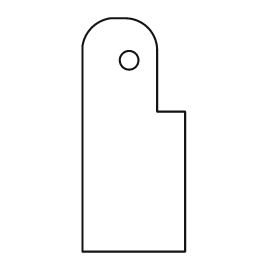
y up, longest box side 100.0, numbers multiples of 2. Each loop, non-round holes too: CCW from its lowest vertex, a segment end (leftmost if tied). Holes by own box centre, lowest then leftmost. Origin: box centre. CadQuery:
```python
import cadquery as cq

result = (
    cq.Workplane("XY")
    .moveTo(-22.0, -50.0)
    .lineTo(22.0, -50.0)
    .lineTo(22.0, 10.0)
    .lineTo(10.0, 10.0)
    .lineTo(10.0, 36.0)
    .threePointArc((6.0, 46.0), (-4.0, 50.0))
    .lineTo(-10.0, 50.0)
    .threePointArc((-18.0, 46.0), (-22.0, 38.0))
    .close()
    .moveTo(-2.0, 32.0)
    .circle(4.0)
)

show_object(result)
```